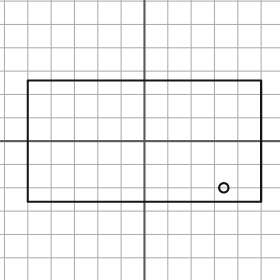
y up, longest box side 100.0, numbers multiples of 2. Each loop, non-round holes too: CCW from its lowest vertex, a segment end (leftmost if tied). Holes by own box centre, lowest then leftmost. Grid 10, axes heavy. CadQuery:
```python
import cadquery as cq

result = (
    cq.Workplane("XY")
    .moveTo(-50.0, -26.0)
    .lineTo(50.0, -26.0)
    .lineTo(50.0, 26.0)
    .lineTo(-50.0, 26.0)
    .close()
    .moveTo(34.0, -20.0)
    .circle(2.0)
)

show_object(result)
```